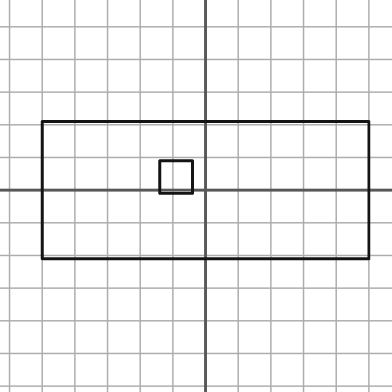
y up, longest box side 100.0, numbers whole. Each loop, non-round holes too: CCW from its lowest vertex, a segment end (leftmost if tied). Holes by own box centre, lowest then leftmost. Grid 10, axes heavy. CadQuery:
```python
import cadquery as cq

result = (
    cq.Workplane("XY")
    .moveTo(-50.0, -21.0)
    .lineTo(50.0, -21.0)
    .lineTo(50.0, 21.0)
    .lineTo(-50.0, 21.0)
    .close()
    .moveTo(-14.0, -1.0)
    .lineTo(-4.0, -1.0)
    .lineTo(-4.0, 9.0)
    .lineTo(-14.0, 9.0)
    .close()
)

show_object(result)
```